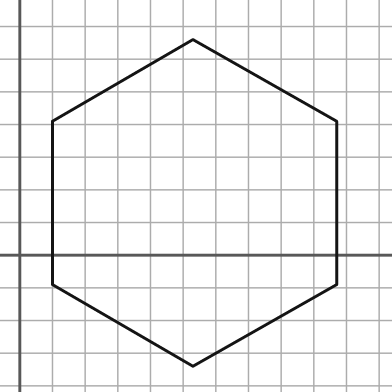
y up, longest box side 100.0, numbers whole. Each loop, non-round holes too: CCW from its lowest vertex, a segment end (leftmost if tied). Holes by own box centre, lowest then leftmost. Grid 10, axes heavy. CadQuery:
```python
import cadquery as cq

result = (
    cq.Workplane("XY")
    .moveTo(53.0, -34.0)
    .lineTo(97.0, -9.0)
    .lineTo(97.0, 41.0)
    .lineTo(53.0, 66.0)
    .lineTo(10.0, 41.0)
    .lineTo(10.0, -9.0)
    .close()
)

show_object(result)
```